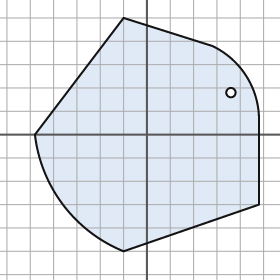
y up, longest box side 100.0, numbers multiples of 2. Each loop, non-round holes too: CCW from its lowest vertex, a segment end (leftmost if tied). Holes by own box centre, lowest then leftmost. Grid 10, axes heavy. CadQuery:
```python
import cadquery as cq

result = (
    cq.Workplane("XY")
    .moveTo(-10.0, -50.0)
    .lineTo(48.0, -30.0)
    .lineTo(48.0, 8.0)
    .threePointArc((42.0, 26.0), (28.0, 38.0))
    .lineTo(-10.0, 50.0)
    .lineTo(-48.0, 0.0)
    .threePointArc((-36.0, -30.0), (-10.0, -50.0))
    .close()
    .moveTo(36.0, 18.0)
    .circle(2.0)
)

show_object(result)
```